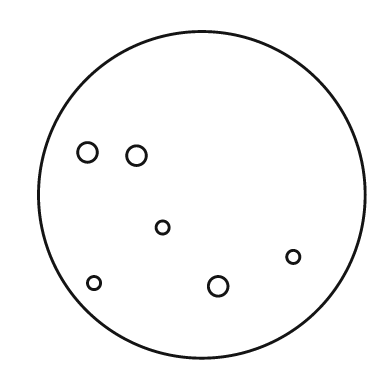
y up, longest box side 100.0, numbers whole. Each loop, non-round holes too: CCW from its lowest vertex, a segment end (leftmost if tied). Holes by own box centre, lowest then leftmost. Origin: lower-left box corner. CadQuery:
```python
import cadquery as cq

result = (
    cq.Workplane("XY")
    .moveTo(50.0, 50.0)
    .circle(50.0)
    .moveTo(55.0, 22.0)
    .circle(3.0)
    .moveTo(17.0, 23.0)
    .circle(2.0)
    .moveTo(78.0, 31.0)
    .circle(2.0)
    .moveTo(38.0, 40.0)
    .circle(2.0)
    .moveTo(30.0, 62.0)
    .circle(3.0)
    .moveTo(15.0, 63.0)
    .circle(3.0)
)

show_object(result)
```